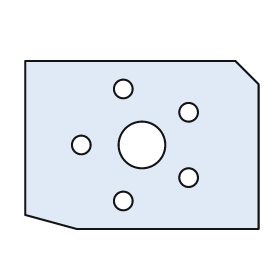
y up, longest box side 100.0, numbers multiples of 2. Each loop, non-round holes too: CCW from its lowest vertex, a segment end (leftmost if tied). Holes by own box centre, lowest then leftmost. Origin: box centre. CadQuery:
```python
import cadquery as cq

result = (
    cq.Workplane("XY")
    .moveTo(-28.0, -36.0)
    .lineTo(50.0, -36.0)
    .lineTo(50.0, 26.0)
    .lineTo(40.0, 36.0)
    .lineTo(-50.0, 36.0)
    .lineTo(-50.0, -30.0)
    .close()
    .moveTo(-8.0, -24.0)
    .circle(4.0)
    .moveTo(20.0, -14.0)
    .circle(4.0)
    .moveTo(-26.0, 0.0)
    .circle(4.0)
    .moveTo(0.0, 0.0)
    .circle(10.0)
    .moveTo(20.0, 14.0)
    .circle(4.0)
    .moveTo(-8.0, 24.0)
    .circle(4.0)
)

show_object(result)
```